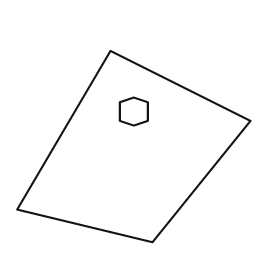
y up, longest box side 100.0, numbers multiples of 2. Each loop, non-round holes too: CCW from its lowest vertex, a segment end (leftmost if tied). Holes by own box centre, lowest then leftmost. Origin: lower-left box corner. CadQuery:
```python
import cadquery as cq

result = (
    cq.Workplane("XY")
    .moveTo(58.0, 0.0)
    .lineTo(100.0, 52.0)
    .lineTo(40.0, 82.0)
    .lineTo(0.0, 14.0)
    .close()
    .moveTo(50.0, 50.0)
    .lineTo(56.0, 52.0)
    .lineTo(56.0, 60.0)
    .lineTo(50.0, 62.0)
    .lineTo(44.0, 60.0)
    .lineTo(44.0, 52.0)
    .close()
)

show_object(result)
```